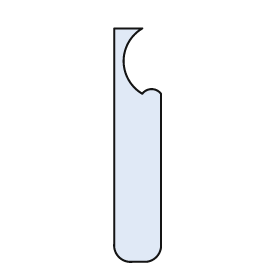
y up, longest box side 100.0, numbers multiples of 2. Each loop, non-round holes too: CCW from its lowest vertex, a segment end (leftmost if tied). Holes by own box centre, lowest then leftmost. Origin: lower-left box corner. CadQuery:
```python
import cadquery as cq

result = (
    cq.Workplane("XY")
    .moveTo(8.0, 0.0)
    .lineTo(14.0, 0.0)
    .threePointArc((18.0, 2.0), (20.0, 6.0))
    .lineTo(20.0, 72.0)
    .threePointArc((16.0, 74.0), (12.0, 72.0))
    .threePointArc((4.0, 86.0), (12.0, 100.0))
    .lineTo(0.0, 100.0)
    .lineTo(0.0, 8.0)
    .threePointArc((2.0, 2.0), (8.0, 0.0))
    .close()
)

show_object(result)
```